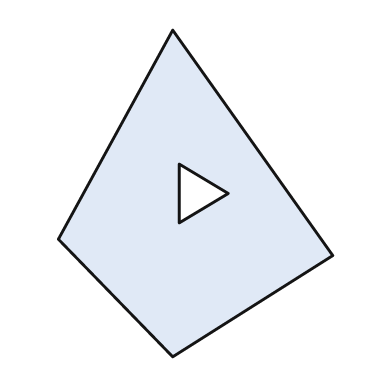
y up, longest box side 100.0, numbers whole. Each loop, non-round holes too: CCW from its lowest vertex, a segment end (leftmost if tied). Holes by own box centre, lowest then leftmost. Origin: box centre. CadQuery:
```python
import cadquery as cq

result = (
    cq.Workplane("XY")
    .moveTo(-7.0, -50.0)
    .lineTo(42.0, -19.0)
    .lineTo(-7.0, 50.0)
    .lineTo(-42.0, -14.0)
    .close()
    .moveTo(-5.0, -9.0)
    .lineTo(10.0, 0.0)
    .lineTo(-5.0, 9.0)
    .close()
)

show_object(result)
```